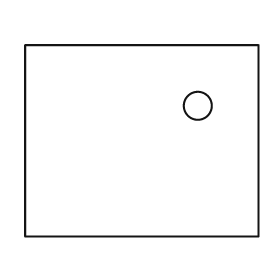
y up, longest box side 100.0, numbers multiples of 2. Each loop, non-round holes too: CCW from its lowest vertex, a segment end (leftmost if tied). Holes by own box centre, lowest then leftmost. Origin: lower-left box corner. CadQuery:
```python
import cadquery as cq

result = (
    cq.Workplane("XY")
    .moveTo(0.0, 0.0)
    .lineTo(100.0, 0.0)
    .lineTo(100.0, 82.0)
    .lineTo(0.0, 82.0)
    .close()
    .moveTo(74.0, 56.0)
    .circle(6.0)
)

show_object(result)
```